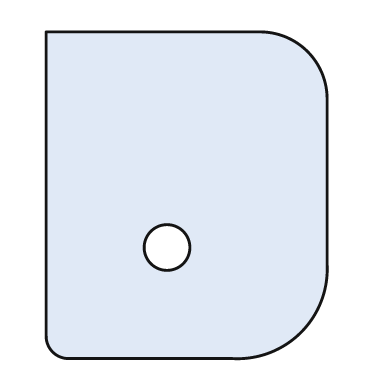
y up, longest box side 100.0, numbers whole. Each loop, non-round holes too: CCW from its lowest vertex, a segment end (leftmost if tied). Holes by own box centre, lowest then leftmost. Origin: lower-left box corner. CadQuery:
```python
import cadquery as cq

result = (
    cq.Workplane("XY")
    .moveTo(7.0, 0.0)
    .lineTo(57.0, 0.0)
    .threePointArc((78.0, 8.0), (86.0, 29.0))
    .lineTo(86.0, 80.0)
    .threePointArc((80.0, 94.0), (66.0, 100.0))
    .lineTo(0.0, 100.0)
    .lineTo(0.0, 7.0)
    .threePointArc((2.0, 2.0), (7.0, 0.0))
    .close()
    .moveTo(37.0, 34.0)
    .circle(7.0)
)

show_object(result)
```